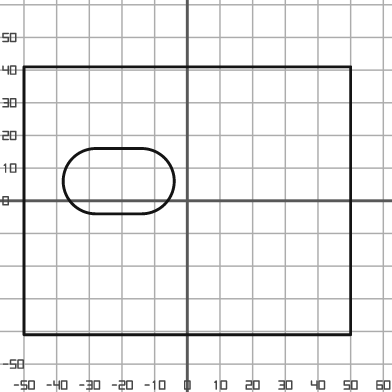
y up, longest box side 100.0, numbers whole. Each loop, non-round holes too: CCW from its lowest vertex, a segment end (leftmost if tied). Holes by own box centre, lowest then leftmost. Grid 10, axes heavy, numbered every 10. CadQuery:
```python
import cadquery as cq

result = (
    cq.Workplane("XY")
    .moveTo(-50.0, -41.0)
    .lineTo(50.0, -41.0)
    .lineTo(50.0, 41.0)
    .lineTo(-50.0, 41.0)
    .close()
    .moveTo(-28.0, -4.0)
    .lineTo(-14.0, -4.0)
    .threePointArc((-4.0, 6.0), (-14.0, 16.0))
    .lineTo(-28.0, 16.0)
    .threePointArc((-38.0, 6.0), (-28.0, -4.0))
    .close()
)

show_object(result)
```